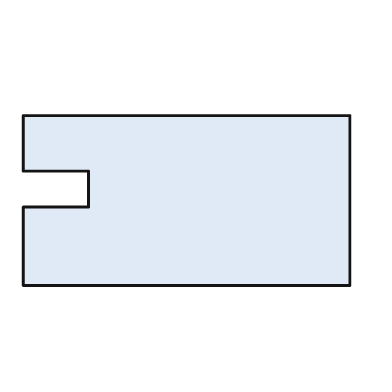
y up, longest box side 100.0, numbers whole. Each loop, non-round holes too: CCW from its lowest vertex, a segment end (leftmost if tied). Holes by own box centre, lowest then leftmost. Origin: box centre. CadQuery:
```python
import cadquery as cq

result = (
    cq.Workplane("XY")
    .moveTo(-50.0, -26.0)
    .lineTo(50.0, -26.0)
    .lineTo(50.0, 26.0)
    .lineTo(-50.0, 26.0)
    .lineTo(-50.0, 9.0)
    .lineTo(-30.0, 9.0)
    .lineTo(-30.0, -2.0)
    .lineTo(-50.0, -2.0)
    .close()
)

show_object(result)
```